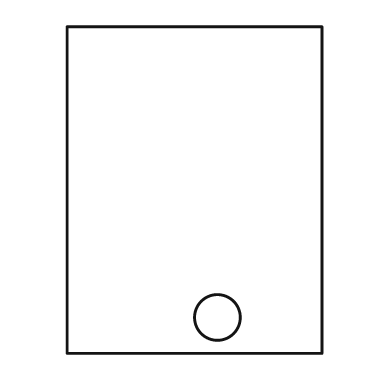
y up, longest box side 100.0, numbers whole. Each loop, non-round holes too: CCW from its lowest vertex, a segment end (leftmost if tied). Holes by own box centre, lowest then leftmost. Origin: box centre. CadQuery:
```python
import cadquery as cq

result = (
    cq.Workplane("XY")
    .moveTo(-39.0, -50.0)
    .lineTo(39.0, -50.0)
    .lineTo(39.0, 50.0)
    .lineTo(-39.0, 50.0)
    .close()
    .moveTo(7.0, -39.0)
    .circle(7.0)
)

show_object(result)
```